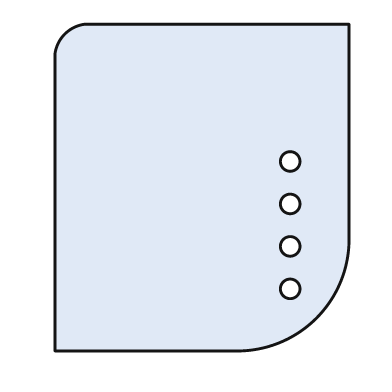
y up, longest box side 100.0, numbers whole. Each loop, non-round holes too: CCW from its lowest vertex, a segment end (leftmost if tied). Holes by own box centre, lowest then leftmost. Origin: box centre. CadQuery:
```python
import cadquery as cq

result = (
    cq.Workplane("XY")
    .moveTo(-45.0, -50.0)
    .lineTo(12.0, -50.0)
    .threePointArc((35.0, -40.0), (45.0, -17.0))
    .lineTo(45.0, 50.0)
    .lineTo(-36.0, 50.0)
    .threePointArc((-42.0, 47.0), (-45.0, 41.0))
    .close()
    .moveTo(27.0, -31.0)
    .circle(3.0)
    .moveTo(27.0, -18.0)
    .circle(3.0)
    .moveTo(27.0, -5.0)
    .circle(3.0)
    .moveTo(27.0, 8.0)
    .circle(3.0)
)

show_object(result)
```